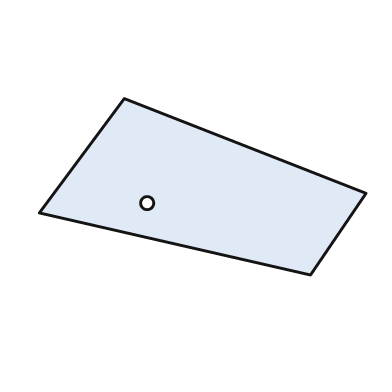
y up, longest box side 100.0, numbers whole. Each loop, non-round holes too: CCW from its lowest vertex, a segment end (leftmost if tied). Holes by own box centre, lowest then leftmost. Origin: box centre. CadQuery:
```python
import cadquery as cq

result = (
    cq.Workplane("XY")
    .moveTo(33.0, -27.0)
    .lineTo(50.0, -2.0)
    .lineTo(-24.0, 27.0)
    .lineTo(-50.0, -8.0)
    .close()
    .moveTo(-17.0, -5.0)
    .circle(2.0)
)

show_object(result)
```